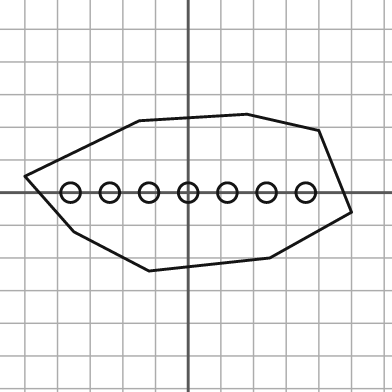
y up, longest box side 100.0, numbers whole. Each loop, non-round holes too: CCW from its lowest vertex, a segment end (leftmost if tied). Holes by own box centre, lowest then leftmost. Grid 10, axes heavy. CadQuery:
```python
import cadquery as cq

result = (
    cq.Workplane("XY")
    .moveTo(-12.0, -24.0)
    .lineTo(25.0, -20.0)
    .lineTo(50.0, -6.0)
    .lineTo(40.0, 19.0)
    .lineTo(18.0, 24.0)
    .lineTo(-15.0, 22.0)
    .lineTo(-50.0, 5.0)
    .lineTo(-35.0, -12.0)
    .close()
    .moveTo(-36.0, 0.0)
    .circle(3.0)
    .moveTo(-24.0, 0.0)
    .circle(3.0)
    .moveTo(-12.0, 0.0)
    .circle(3.0)
    .moveTo(0.0, 0.0)
    .circle(3.0)
    .moveTo(12.0, 0.0)
    .circle(3.0)
    .moveTo(24.0, 0.0)
    .circle(3.0)
    .moveTo(36.0, 0.0)
    .circle(3.0)
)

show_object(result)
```